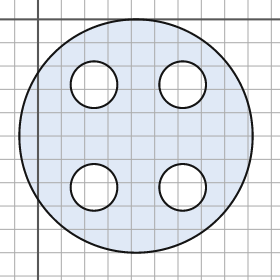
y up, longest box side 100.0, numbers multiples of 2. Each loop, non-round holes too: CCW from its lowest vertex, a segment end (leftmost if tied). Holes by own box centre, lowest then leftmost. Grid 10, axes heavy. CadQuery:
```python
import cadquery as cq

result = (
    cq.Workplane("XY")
    .moveTo(42.0, -50.0)
    .circle(50.0)
    .moveTo(24.0, -72.0)
    .circle(10.0)
    .moveTo(62.0, -72.0)
    .circle(10.0)
    .moveTo(24.0, -28.0)
    .circle(10.0)
    .moveTo(62.0, -28.0)
    .circle(10.0)
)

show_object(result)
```